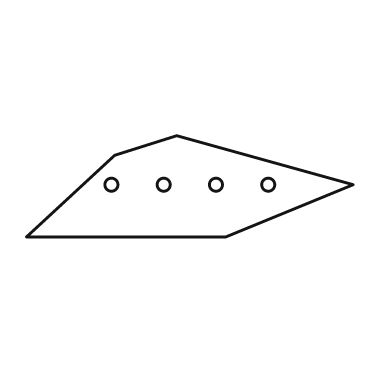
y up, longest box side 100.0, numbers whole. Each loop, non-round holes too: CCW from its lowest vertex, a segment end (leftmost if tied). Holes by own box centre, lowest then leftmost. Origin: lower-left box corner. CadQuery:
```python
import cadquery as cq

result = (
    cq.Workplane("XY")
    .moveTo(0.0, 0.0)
    .lineTo(61.0, 0.0)
    .lineTo(100.0, 16.0)
    .lineTo(46.0, 31.0)
    .lineTo(27.0, 25.0)
    .close()
    .moveTo(26.0, 16.0)
    .circle(2.0)
    .moveTo(42.0, 16.0)
    .circle(2.0)
    .moveTo(58.0, 16.0)
    .circle(2.0)
    .moveTo(74.0, 16.0)
    .circle(2.0)
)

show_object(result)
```